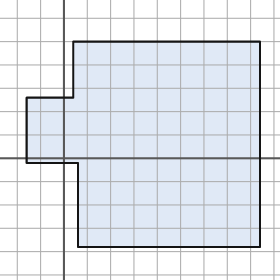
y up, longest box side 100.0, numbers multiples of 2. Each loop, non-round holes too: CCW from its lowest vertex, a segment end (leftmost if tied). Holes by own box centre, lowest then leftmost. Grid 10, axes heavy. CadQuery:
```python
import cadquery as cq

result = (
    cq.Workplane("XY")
    .moveTo(6.0, -38.0)
    .lineTo(84.0, -38.0)
    .lineTo(84.0, 50.0)
    .lineTo(4.0, 50.0)
    .lineTo(4.0, 26.0)
    .lineTo(-16.0, 26.0)
    .lineTo(-16.0, -2.0)
    .lineTo(6.0, -2.0)
    .close()
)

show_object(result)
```